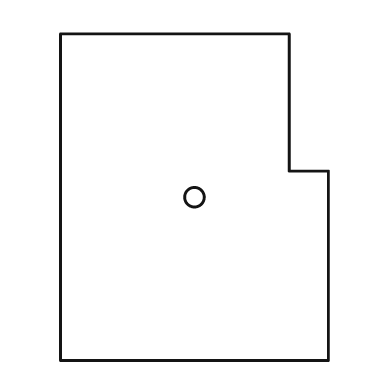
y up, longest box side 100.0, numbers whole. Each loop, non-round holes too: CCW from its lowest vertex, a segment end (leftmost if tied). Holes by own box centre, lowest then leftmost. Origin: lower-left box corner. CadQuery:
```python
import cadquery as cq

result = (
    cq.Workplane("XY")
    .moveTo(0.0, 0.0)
    .lineTo(82.0, 0.0)
    .lineTo(82.0, 58.0)
    .lineTo(70.0, 58.0)
    .lineTo(70.0, 100.0)
    .lineTo(0.0, 100.0)
    .close()
    .moveTo(41.0, 50.0)
    .circle(3.0)
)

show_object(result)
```